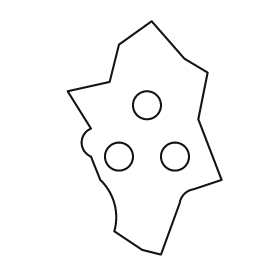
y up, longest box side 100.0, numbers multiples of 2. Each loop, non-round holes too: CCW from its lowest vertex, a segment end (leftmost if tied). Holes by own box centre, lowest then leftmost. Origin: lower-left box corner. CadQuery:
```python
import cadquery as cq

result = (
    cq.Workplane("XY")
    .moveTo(40.0, 0.0)
    .lineTo(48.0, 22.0)
    .threePointArc((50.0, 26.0), (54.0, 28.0))
    .lineTo(66.0, 32.0)
    .lineTo(56.0, 58.0)
    .lineTo(60.0, 78.0)
    .lineTo(50.0, 84.0)
    .lineTo(36.0, 100.0)
    .lineTo(22.0, 90.0)
    .lineTo(18.0, 74.0)
    .lineTo(0.0, 70.0)
    .lineTo(10.0, 54.0)
    .threePointArc((6.0, 48.0), (10.0, 42.0))
    .lineTo(14.0, 32.0)
    .threePointArc((20.0, 22.0), (20.0, 10.0))
    .lineTo(32.0, 2.0)
    .close()
    .moveTo(22.0, 42.0)
    .circle(6.0)
    .moveTo(46.0, 42.0)
    .circle(6.0)
    .moveTo(34.0, 64.0)
    .circle(6.0)
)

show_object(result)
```